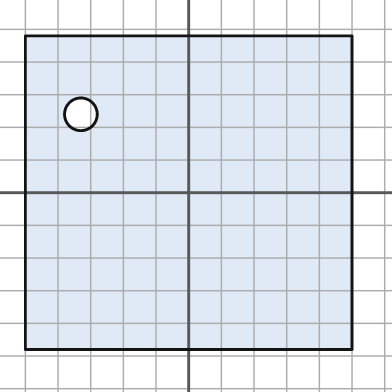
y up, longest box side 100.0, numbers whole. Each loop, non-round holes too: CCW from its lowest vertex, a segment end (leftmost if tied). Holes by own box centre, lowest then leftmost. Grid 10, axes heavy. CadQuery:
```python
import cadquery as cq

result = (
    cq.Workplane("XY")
    .moveTo(-50.0, -48.0)
    .lineTo(50.0, -48.0)
    .lineTo(50.0, 48.0)
    .lineTo(-50.0, 48.0)
    .close()
    .moveTo(-33.0, 24.0)
    .circle(5.0)
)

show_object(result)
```